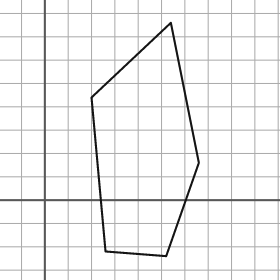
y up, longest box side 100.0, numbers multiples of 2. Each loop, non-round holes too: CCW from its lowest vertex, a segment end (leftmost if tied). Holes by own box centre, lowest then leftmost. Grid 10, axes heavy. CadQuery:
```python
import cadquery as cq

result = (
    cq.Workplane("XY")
    .moveTo(52.0, -24.0)
    .lineTo(66.0, 16.0)
    .lineTo(54.0, 76.0)
    .lineTo(20.0, 44.0)
    .lineTo(26.0, -22.0)
    .close()
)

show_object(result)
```